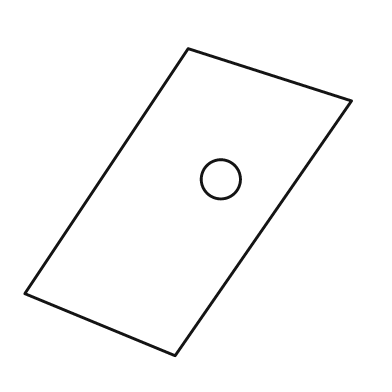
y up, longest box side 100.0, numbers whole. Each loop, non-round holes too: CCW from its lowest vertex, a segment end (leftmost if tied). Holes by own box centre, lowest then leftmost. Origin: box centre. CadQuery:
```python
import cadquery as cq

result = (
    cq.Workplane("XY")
    .moveTo(-4.0, -47.0)
    .lineTo(50.0, 31.0)
    .lineTo(0.0, 47.0)
    .lineTo(-50.0, -28.0)
    .close()
    .moveTo(10.0, 7.0)
    .circle(6.0)
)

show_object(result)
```